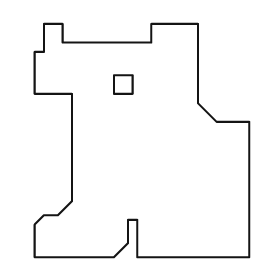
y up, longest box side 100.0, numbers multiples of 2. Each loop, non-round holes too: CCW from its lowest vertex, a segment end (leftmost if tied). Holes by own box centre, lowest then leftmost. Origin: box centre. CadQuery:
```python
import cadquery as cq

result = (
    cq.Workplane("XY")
    .moveTo(-46.0, -50.0)
    .lineTo(-12.0, -50.0)
    .lineTo(-6.0, -44.0)
    .lineTo(-6.0, -34.0)
    .lineTo(-2.0, -34.0)
    .lineTo(-2.0, -50.0)
    .lineTo(46.0, -50.0)
    .lineTo(46.0, 8.0)
    .lineTo(32.0, 8.0)
    .lineTo(24.0, 16.0)
    .lineTo(24.0, 50.0)
    .lineTo(4.0, 50.0)
    .lineTo(4.0, 42.0)
    .lineTo(-34.0, 42.0)
    .lineTo(-34.0, 50.0)
    .lineTo(-42.0, 50.0)
    .lineTo(-42.0, 38.0)
    .lineTo(-46.0, 38.0)
    .lineTo(-46.0, 20.0)
    .lineTo(-30.0, 20.0)
    .lineTo(-30.0, -26.0)
    .lineTo(-36.0, -32.0)
    .lineTo(-42.0, -32.0)
    .lineTo(-46.0, -36.0)
    .close()
    .moveTo(-12.0, 20.0)
    .lineTo(-4.0, 20.0)
    .lineTo(-4.0, 28.0)
    .lineTo(-12.0, 28.0)
    .close()
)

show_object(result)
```